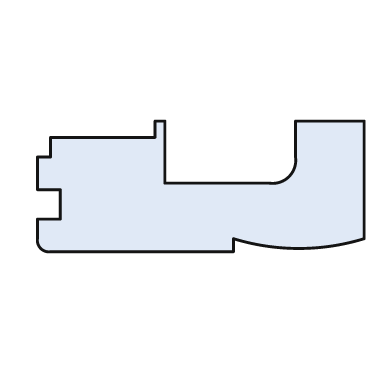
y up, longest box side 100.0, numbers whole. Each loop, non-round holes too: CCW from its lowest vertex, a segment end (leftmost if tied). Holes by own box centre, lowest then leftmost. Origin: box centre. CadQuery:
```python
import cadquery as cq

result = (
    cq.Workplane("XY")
    .moveTo(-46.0, -20.0)
    .lineTo(10.0, -20.0)
    .lineTo(10.0, -16.0)
    .threePointArc((30.0, -19.0), (50.0, -16.0))
    .lineTo(50.0, 20.0)
    .lineTo(29.0, 20.0)
    .lineTo(29.0, 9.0)
    .threePointArc((27.0, 3.0), (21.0, 1.0))
    .lineTo(-11.0, 1.0)
    .lineTo(-11.0, 20.0)
    .lineTo(-14.0, 20.0)
    .lineTo(-14.0, 15.0)
    .lineTo(-46.0, 15.0)
    .lineTo(-46.0, 9.0)
    .lineTo(-50.0, 9.0)
    .lineTo(-50.0, -1.0)
    .lineTo(-43.0, -1.0)
    .lineTo(-43.0, -10.0)
    .lineTo(-50.0, -10.0)
    .lineTo(-50.0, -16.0)
    .threePointArc((-49.0, -19.0), (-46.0, -20.0))
    .close()
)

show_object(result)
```